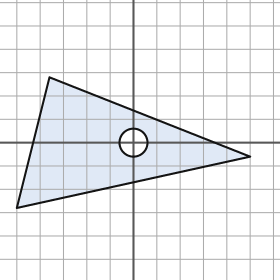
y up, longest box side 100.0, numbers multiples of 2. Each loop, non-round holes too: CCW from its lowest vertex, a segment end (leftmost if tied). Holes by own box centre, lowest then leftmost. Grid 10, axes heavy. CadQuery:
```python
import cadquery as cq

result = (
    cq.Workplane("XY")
    .moveTo(-50.0, -28.0)
    .lineTo(50.0, -6.0)
    .lineTo(-36.0, 28.0)
    .close()
    .moveTo(0.0, 0.0)
    .circle(6.0)
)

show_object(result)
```